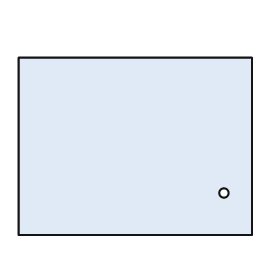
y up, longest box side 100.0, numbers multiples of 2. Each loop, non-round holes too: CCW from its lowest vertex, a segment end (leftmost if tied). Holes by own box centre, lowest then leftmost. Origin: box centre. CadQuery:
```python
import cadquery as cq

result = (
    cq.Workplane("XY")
    .moveTo(-50.0, -38.0)
    .lineTo(50.0, -38.0)
    .lineTo(50.0, 38.0)
    .lineTo(-50.0, 38.0)
    .close()
    .moveTo(38.0, -20.0)
    .circle(2.0)
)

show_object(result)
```